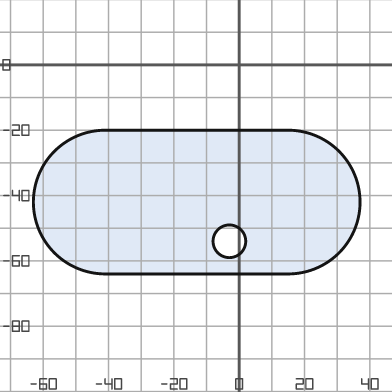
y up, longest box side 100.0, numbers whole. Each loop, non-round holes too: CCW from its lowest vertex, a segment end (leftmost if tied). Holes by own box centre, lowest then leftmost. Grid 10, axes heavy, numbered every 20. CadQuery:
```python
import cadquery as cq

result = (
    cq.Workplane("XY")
    .moveTo(-41.0, -64.0)
    .lineTo(15.0, -64.0)
    .threePointArc((37.0, -42.0), (15.0, -20.0))
    .lineTo(-41.0, -20.0)
    .threePointArc((-63.0, -42.0), (-41.0, -64.0))
    .close()
    .moveTo(-3.0, -54.0)
    .circle(5.0)
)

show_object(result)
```